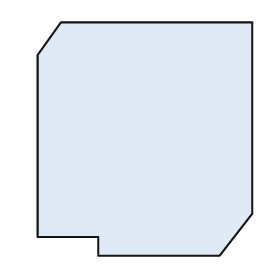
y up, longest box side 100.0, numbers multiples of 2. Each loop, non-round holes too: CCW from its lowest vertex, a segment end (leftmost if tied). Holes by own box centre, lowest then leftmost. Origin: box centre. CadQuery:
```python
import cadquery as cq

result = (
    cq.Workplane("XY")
    .moveTo(-20.0, -50.0)
    .lineTo(32.0, -50.0)
    .lineTo(46.0, -32.0)
    .lineTo(46.0, 50.0)
    .lineTo(-36.0, 50.0)
    .lineTo(-46.0, 36.0)
    .lineTo(-46.0, -42.0)
    .lineTo(-20.0, -42.0)
    .close()
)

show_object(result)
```